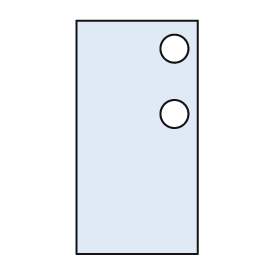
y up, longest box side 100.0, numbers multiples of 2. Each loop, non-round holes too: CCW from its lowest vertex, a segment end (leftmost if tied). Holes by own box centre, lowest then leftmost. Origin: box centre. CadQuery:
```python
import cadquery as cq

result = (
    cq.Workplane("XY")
    .moveTo(-26.0, -50.0)
    .lineTo(26.0, -50.0)
    .lineTo(26.0, 50.0)
    .lineTo(-26.0, 50.0)
    .close()
    .moveTo(16.0, 10.0)
    .circle(6.0)
    .moveTo(16.0, 38.0)
    .circle(6.0)
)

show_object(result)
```